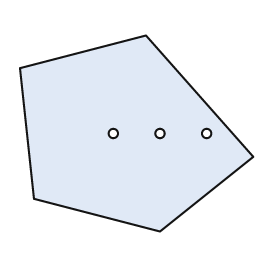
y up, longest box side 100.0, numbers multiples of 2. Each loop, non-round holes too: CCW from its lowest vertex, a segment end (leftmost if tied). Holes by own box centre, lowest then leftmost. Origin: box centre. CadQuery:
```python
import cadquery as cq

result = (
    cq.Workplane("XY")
    .moveTo(10.0, -42.0)
    .lineTo(50.0, -10.0)
    .lineTo(4.0, 42.0)
    .lineTo(-50.0, 28.0)
    .lineTo(-44.0, -28.0)
    .close()
    .moveTo(-10.0, 0.0)
    .circle(2.0)
    .moveTo(10.0, 0.0)
    .circle(2.0)
    .moveTo(30.0, 0.0)
    .circle(2.0)
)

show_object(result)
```